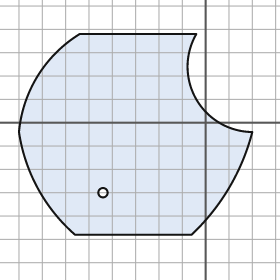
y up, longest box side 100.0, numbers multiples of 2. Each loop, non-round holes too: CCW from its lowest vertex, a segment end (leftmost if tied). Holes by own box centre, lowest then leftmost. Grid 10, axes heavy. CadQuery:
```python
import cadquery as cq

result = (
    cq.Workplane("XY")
    .moveTo(-56.0, -48.0)
    .lineTo(-6.0, -48.0)
    .threePointArc((10.0, -28.0), (20.0, -4.0))
    .threePointArc((-4.0, 10.0), (-4.0, 38.0))
    .lineTo(-54.0, 38.0)
    .threePointArc((-72.0, 20.0), (-80.0, -4.0))
    .threePointArc((-72.0, -28.0), (-56.0, -48.0))
    .close()
    .moveTo(-44.0, -30.0)
    .circle(2.0)
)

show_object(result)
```